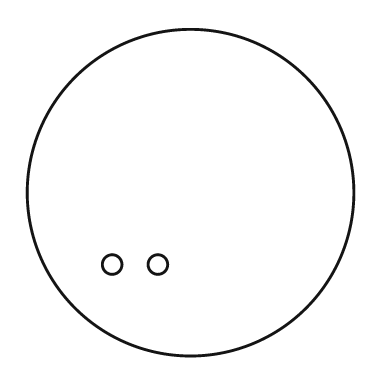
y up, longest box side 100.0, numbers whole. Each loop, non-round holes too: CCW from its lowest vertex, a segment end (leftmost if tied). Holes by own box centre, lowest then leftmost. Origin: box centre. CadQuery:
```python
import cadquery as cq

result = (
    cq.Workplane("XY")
    .moveTo(0.0, 0.0)
    .circle(50.0)
    .moveTo(-24.0, -22.0)
    .circle(3.0)
    .moveTo(-10.0, -22.0)
    .circle(3.0)
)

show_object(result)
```